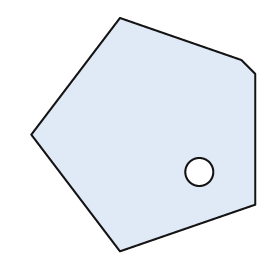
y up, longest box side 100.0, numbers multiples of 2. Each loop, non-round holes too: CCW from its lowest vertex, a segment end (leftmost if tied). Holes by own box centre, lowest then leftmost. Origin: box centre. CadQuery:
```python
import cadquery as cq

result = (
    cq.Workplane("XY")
    .moveTo(-10.0, -50.0)
    .lineTo(48.0, -30.0)
    .lineTo(48.0, 26.0)
    .lineTo(42.0, 32.0)
    .lineTo(-10.0, 50.0)
    .lineTo(-48.0, 0.0)
    .close()
    .moveTo(24.0, -16.0)
    .circle(6.0)
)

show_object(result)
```